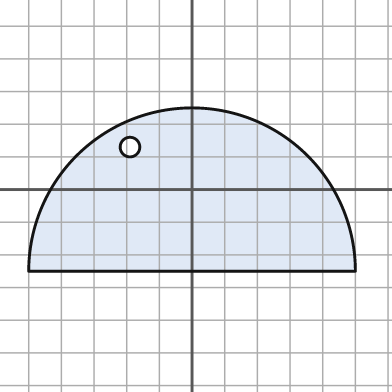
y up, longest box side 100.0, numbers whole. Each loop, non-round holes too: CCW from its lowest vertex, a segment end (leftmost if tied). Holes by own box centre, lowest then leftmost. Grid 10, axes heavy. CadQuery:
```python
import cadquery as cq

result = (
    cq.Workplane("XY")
    .moveTo(-50.0, -25.0)
    .lineTo(50.0, -25.0)
    .threePointArc((0.0, 25.0), (-50.0, -25.0))
    .close()
    .moveTo(-19.0, 13.0)
    .circle(3.0)
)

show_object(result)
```